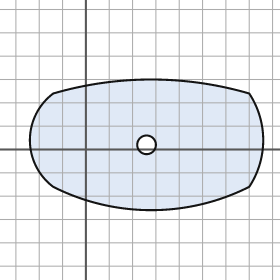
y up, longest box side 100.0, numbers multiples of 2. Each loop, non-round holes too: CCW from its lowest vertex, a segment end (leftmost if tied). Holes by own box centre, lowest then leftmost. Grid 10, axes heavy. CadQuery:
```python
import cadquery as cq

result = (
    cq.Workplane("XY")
    .moveTo(-14.0, -16.0)
    .threePointArc((28.0, -26.0), (70.0, -16.0))
    .threePointArc((76.0, 4.0), (70.0, 24.0))
    .threePointArc((28.0, 30.0), (-14.0, 24.0))
    .threePointArc((-24.0, 4.0), (-14.0, -16.0))
    .close()
    .moveTo(26.0, 2.0)
    .circle(4.0)
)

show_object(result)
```